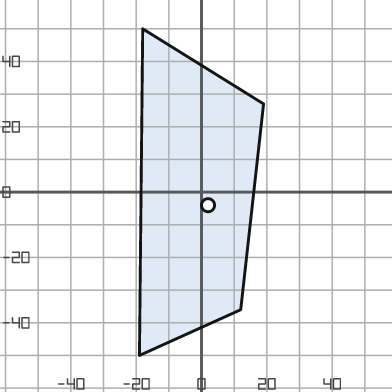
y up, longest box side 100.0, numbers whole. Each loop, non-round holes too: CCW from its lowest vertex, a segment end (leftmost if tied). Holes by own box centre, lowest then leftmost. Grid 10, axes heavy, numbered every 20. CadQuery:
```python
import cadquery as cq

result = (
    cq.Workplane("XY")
    .moveTo(-19.0, -50.0)
    .lineTo(12.0, -36.0)
    .lineTo(19.0, 27.0)
    .lineTo(-18.0, 50.0)
    .close()
    .moveTo(2.0, -4.0)
    .circle(2.0)
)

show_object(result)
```